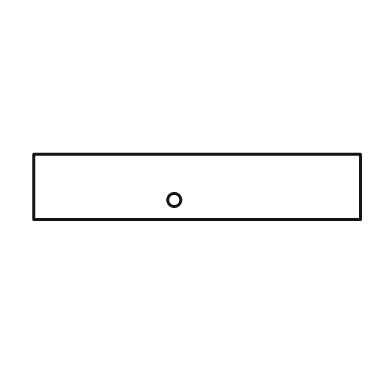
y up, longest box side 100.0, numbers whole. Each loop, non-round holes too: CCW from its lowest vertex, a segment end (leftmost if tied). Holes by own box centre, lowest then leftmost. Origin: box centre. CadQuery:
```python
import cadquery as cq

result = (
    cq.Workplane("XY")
    .moveTo(-50.0, -10.0)
    .lineTo(50.0, -10.0)
    .lineTo(50.0, 10.0)
    .lineTo(-50.0, 10.0)
    .close()
    .moveTo(-7.0, -4.0)
    .circle(2.0)
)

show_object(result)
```